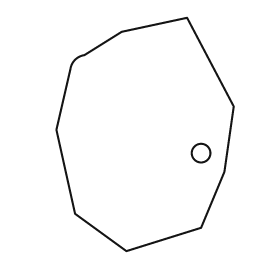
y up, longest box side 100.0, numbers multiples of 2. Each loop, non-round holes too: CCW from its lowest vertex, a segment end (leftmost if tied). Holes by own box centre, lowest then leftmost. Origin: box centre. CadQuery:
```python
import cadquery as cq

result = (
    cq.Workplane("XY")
    .moveTo(-8.0, -50.0)
    .lineTo(24.0, -40.0)
    .lineTo(34.0, -16.0)
    .lineTo(38.0, 12.0)
    .lineTo(18.0, 50.0)
    .lineTo(-10.0, 44.0)
    .lineTo(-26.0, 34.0)
    .threePointArc((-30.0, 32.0), (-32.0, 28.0))
    .lineTo(-38.0, 2.0)
    .lineTo(-30.0, -34.0)
    .close()
    .moveTo(24.0, -8.0)
    .circle(4.0)
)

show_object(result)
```